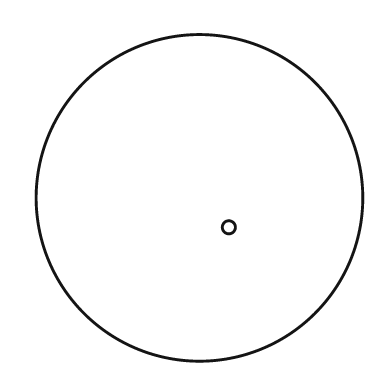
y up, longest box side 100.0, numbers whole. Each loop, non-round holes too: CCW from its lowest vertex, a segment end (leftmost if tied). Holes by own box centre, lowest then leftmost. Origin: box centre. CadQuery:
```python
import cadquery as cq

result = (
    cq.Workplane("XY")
    .moveTo(0.0, 0.0)
    .circle(50.0)
    .moveTo(9.0, -9.0)
    .circle(2.0)
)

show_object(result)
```